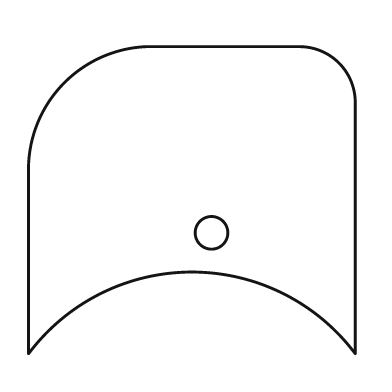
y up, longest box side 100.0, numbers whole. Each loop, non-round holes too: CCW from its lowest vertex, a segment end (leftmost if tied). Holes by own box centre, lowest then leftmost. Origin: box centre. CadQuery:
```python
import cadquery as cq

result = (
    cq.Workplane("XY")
    .moveTo(-50.0, -47.0)
    .threePointArc((0.0, -22.0), (50.0, -47.0))
    .lineTo(50.0, 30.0)
    .threePointArc((45.0, 42.0), (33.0, 47.0))
    .lineTo(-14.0, 47.0)
    .threePointArc((-39.0, 36.0), (-50.0, 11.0))
    .close()
    .moveTo(6.0, -10.0)
    .circle(5.0)
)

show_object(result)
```